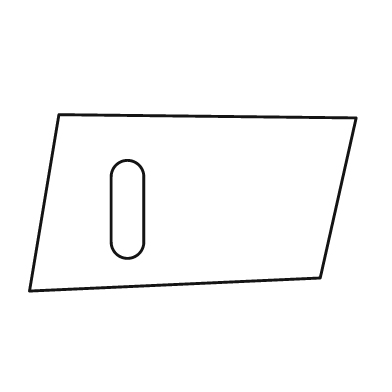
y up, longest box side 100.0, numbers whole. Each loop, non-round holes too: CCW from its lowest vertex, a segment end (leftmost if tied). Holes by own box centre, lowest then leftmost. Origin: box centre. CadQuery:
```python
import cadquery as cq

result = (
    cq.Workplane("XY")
    .moveTo(-50.0, -27.0)
    .lineTo(39.0, -23.0)
    .lineTo(50.0, 26.0)
    .lineTo(-41.0, 27.0)
    .close()
    .moveTo(-25.0, -12.0)
    .threePointArc((-20.0, -17.0), (-15.0, -12.0))
    .lineTo(-15.0, 8.0)
    .threePointArc((-20.0, 13.0), (-25.0, 8.0))
    .close()
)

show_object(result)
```